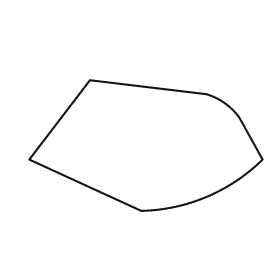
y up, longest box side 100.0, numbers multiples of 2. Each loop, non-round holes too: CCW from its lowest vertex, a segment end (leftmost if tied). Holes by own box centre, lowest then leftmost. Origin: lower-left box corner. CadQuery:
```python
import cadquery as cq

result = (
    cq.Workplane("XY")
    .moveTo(48.0, 0.0)
    .threePointArc((76.0, 6.0), (100.0, 22.0))
    .lineTo(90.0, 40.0)
    .threePointArc((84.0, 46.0), (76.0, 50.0))
    .lineTo(26.0, 56.0)
    .lineTo(0.0, 22.0)
    .close()
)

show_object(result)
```